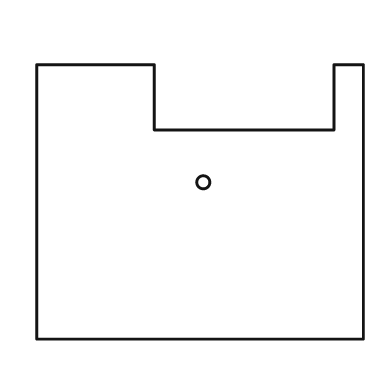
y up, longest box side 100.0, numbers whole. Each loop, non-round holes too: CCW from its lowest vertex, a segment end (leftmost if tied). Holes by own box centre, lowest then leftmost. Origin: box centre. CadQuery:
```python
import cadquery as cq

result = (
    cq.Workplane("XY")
    .moveTo(-50.0, -42.0)
    .lineTo(50.0, -42.0)
    .lineTo(50.0, 42.0)
    .lineTo(41.0, 42.0)
    .lineTo(41.0, 22.0)
    .lineTo(-14.0, 22.0)
    .lineTo(-14.0, 42.0)
    .lineTo(-50.0, 42.0)
    .close()
    .moveTo(1.0, 6.0)
    .circle(2.0)
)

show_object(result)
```